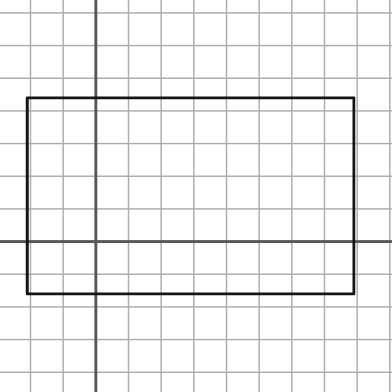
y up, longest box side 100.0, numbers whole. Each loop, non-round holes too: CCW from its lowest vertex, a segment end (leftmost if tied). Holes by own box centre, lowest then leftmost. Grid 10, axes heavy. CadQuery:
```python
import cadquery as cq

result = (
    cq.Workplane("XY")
    .moveTo(-21.0, -16.0)
    .lineTo(79.0, -16.0)
    .lineTo(79.0, 44.0)
    .lineTo(-21.0, 44.0)
    .close()
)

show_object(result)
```